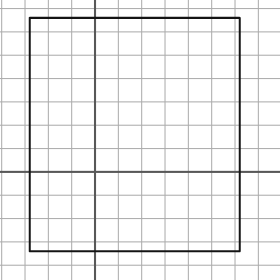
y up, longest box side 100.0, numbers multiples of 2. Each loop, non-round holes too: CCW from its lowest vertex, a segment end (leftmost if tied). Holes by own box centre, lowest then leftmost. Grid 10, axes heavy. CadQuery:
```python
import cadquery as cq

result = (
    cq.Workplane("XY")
    .moveTo(-28.0, -34.0)
    .lineTo(62.0, -34.0)
    .lineTo(62.0, 66.0)
    .lineTo(-28.0, 66.0)
    .close()
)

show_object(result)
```